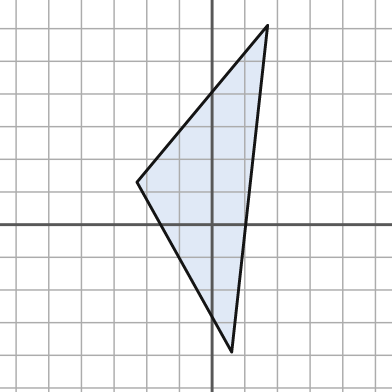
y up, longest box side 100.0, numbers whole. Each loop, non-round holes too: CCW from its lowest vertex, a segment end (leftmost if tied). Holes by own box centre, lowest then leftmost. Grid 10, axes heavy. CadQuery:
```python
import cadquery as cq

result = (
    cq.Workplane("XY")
    .moveTo(6.0, -39.0)
    .lineTo(17.0, 61.0)
    .lineTo(-23.0, 13.0)
    .close()
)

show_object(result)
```